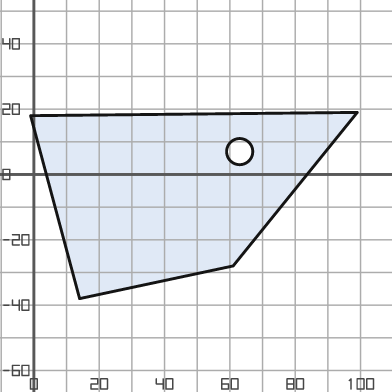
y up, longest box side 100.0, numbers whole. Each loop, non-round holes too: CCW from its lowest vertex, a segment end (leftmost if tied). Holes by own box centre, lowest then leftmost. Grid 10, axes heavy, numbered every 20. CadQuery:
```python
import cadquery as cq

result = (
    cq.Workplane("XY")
    .moveTo(14.0, -38.0)
    .lineTo(61.0, -28.0)
    .lineTo(99.0, 19.0)
    .lineTo(-1.0, 18.0)
    .close()
    .moveTo(63.0, 7.0)
    .circle(4.0)
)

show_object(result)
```